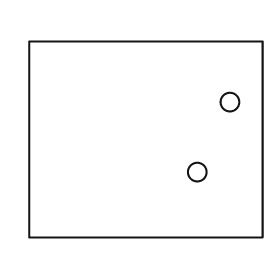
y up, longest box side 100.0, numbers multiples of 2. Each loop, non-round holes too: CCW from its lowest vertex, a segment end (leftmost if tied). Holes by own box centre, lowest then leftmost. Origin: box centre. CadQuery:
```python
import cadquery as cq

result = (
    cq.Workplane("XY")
    .moveTo(-50.0, -42.0)
    .lineTo(50.0, -42.0)
    .lineTo(50.0, 42.0)
    .lineTo(-50.0, 42.0)
    .close()
    .moveTo(22.0, -14.0)
    .circle(4.0)
    .moveTo(36.0, 16.0)
    .circle(4.0)
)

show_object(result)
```